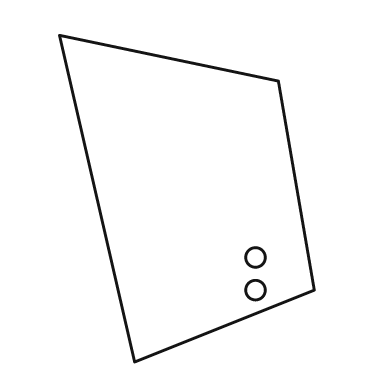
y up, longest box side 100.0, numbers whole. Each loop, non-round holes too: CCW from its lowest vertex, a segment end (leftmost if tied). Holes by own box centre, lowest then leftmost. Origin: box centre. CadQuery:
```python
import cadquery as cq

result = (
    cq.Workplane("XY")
    .moveTo(-16.0, -50.0)
    .lineTo(39.0, -28.0)
    .lineTo(28.0, 36.0)
    .lineTo(-39.0, 50.0)
    .close()
    .moveTo(21.0, -28.0)
    .circle(3.0)
    .moveTo(21.0, -18.0)
    .circle(3.0)
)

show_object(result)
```